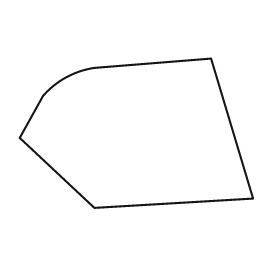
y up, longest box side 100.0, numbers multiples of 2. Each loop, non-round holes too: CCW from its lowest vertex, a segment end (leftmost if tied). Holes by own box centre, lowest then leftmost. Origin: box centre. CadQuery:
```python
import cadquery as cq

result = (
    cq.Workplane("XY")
    .moveTo(-18.0, -32.0)
    .lineTo(50.0, -28.0)
    .lineTo(32.0, 32.0)
    .lineTo(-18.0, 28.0)
    .threePointArc((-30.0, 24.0), (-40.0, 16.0))
    .lineTo(-50.0, -2.0)
    .close()
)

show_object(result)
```